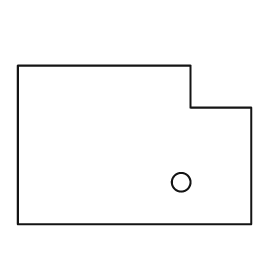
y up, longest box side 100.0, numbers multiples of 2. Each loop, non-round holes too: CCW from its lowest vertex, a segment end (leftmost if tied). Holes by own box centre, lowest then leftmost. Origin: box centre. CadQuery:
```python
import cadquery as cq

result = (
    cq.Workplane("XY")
    .moveTo(-50.0, -34.0)
    .lineTo(50.0, -34.0)
    .lineTo(50.0, 16.0)
    .lineTo(24.0, 16.0)
    .lineTo(24.0, 34.0)
    .lineTo(-50.0, 34.0)
    .close()
    .moveTo(20.0, -16.0)
    .circle(4.0)
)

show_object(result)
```